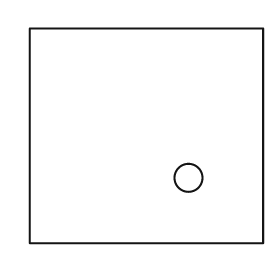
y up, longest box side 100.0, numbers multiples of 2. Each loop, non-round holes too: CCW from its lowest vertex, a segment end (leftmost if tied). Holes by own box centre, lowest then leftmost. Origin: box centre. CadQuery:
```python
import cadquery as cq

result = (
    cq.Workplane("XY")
    .moveTo(-50.0, -46.0)
    .lineTo(50.0, -46.0)
    .lineTo(50.0, 46.0)
    .lineTo(-50.0, 46.0)
    .close()
    .moveTo(18.0, -18.0)
    .circle(6.0)
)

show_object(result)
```